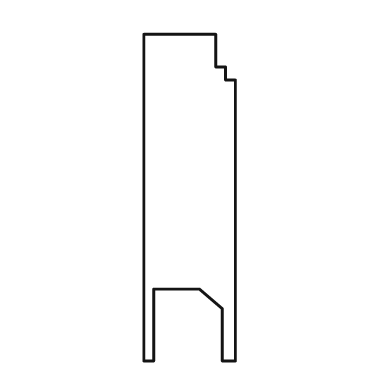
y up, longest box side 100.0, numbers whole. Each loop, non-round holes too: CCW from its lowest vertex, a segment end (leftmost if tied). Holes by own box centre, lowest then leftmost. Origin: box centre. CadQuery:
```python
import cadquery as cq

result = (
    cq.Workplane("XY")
    .moveTo(-14.0, -50.0)
    .lineTo(-11.0, -50.0)
    .lineTo(-11.0, -28.0)
    .lineTo(3.0, -28.0)
    .lineTo(10.0, -34.0)
    .lineTo(10.0, -50.0)
    .lineTo(14.0, -50.0)
    .lineTo(14.0, 36.0)
    .lineTo(11.0, 36.0)
    .lineTo(11.0, 40.0)
    .lineTo(8.0, 40.0)
    .lineTo(8.0, 50.0)
    .lineTo(-14.0, 50.0)
    .close()
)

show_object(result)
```